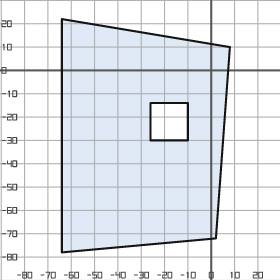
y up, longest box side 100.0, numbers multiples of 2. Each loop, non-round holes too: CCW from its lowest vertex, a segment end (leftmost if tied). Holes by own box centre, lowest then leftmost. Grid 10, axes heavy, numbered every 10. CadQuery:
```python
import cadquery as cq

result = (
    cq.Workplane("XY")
    .moveTo(-64.0, -78.0)
    .lineTo(2.0, -72.0)
    .lineTo(8.0, 10.0)
    .lineTo(-64.0, 22.0)
    .close()
    .moveTo(-26.0, -30.0)
    .lineTo(-10.0, -30.0)
    .lineTo(-10.0, -14.0)
    .lineTo(-26.0, -14.0)
    .close()
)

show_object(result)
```